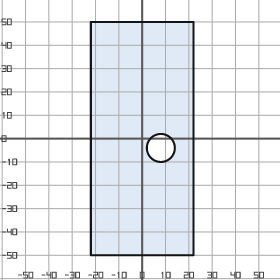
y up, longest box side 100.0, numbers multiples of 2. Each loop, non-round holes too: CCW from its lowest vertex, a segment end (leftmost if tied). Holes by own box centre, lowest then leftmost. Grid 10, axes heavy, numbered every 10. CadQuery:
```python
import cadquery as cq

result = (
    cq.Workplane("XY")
    .moveTo(-22.0, -50.0)
    .lineTo(22.0, -50.0)
    .lineTo(22.0, 50.0)
    .lineTo(-22.0, 50.0)
    .close()
    .moveTo(8.0, -4.0)
    .circle(6.0)
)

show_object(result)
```